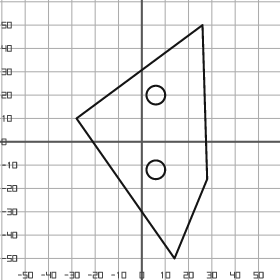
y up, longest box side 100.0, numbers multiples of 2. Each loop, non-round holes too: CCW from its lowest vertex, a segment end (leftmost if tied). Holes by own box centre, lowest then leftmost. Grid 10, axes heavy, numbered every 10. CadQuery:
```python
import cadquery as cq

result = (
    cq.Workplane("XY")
    .moveTo(14.0, -50.0)
    .lineTo(28.0, -16.0)
    .lineTo(26.0, 50.0)
    .lineTo(-28.0, 10.0)
    .close()
    .moveTo(6.0, -12.0)
    .circle(4.0)
    .moveTo(6.0, 20.0)
    .circle(4.0)
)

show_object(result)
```